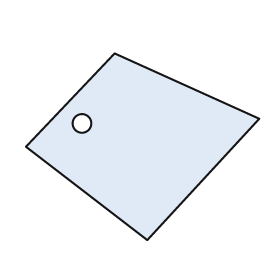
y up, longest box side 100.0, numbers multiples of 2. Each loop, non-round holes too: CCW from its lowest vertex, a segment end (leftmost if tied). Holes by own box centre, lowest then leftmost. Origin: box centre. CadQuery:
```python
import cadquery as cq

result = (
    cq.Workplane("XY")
    .moveTo(2.0, -40.0)
    .lineTo(50.0, 12.0)
    .lineTo(-12.0, 40.0)
    .lineTo(-50.0, 0.0)
    .close()
    .moveTo(-26.0, 10.0)
    .circle(4.0)
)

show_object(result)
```